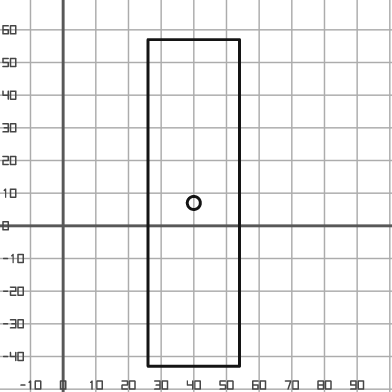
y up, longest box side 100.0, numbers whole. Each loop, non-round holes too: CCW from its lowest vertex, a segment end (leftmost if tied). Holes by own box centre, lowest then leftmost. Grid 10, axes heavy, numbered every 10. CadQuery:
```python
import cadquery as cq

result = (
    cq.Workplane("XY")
    .moveTo(26.0, -43.0)
    .lineTo(54.0, -43.0)
    .lineTo(54.0, 57.0)
    .lineTo(26.0, 57.0)
    .close()
    .moveTo(40.0, 7.0)
    .circle(2.0)
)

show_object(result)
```